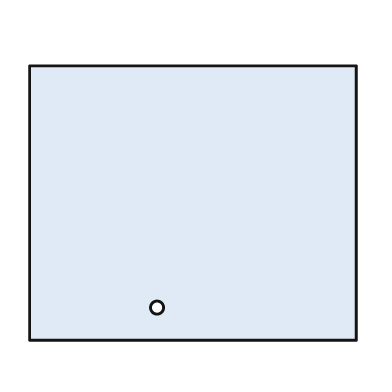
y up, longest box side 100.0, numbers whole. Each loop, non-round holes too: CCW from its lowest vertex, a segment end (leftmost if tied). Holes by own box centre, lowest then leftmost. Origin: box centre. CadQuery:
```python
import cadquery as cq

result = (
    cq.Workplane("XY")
    .moveTo(-50.0, -42.0)
    .lineTo(50.0, -42.0)
    .lineTo(50.0, 42.0)
    .lineTo(-50.0, 42.0)
    .close()
    .moveTo(-11.0, -32.0)
    .circle(2.0)
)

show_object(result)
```